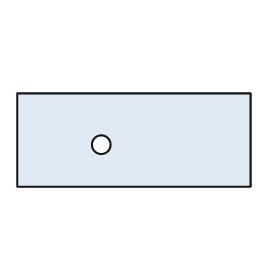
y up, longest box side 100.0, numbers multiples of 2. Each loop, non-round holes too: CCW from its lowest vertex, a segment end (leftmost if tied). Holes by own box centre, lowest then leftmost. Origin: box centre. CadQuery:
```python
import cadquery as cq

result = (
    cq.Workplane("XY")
    .moveTo(-50.0, -20.0)
    .lineTo(50.0, -20.0)
    .lineTo(50.0, 20.0)
    .lineTo(-50.0, 20.0)
    .close()
    .moveTo(-14.0, -2.0)
    .circle(4.0)
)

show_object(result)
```